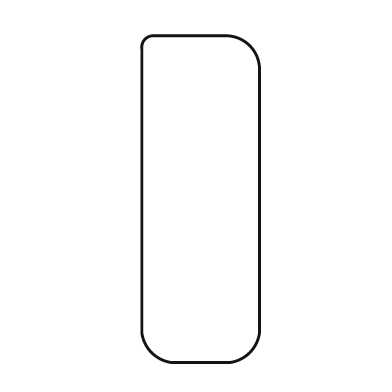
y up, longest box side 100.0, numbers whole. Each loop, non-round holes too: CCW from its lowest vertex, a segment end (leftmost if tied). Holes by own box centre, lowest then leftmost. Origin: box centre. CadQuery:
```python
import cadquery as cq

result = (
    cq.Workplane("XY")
    .moveTo(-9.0, -50.0)
    .lineTo(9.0, -50.0)
    .threePointArc((15.0, -47.0), (18.0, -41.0))
    .lineTo(18.0, 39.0)
    .threePointArc((15.0, 47.0), (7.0, 50.0))
    .lineTo(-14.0, 50.0)
    .threePointArc((-17.0, 49.0), (-18.0, 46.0))
    .lineTo(-18.0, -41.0)
    .threePointArc((-15.0, -47.0), (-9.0, -50.0))
    .close()
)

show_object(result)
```